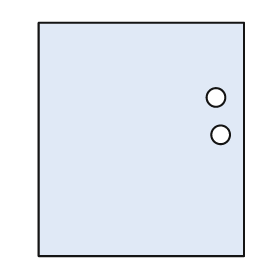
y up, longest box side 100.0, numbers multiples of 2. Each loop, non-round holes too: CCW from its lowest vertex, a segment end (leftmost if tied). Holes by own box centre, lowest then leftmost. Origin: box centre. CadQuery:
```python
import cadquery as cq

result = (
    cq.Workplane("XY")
    .moveTo(-44.0, -50.0)
    .lineTo(44.0, -50.0)
    .lineTo(44.0, 50.0)
    .lineTo(-44.0, 50.0)
    .close()
    .moveTo(34.0, 2.0)
    .circle(4.0)
    .moveTo(32.0, 18.0)
    .circle(4.0)
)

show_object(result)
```